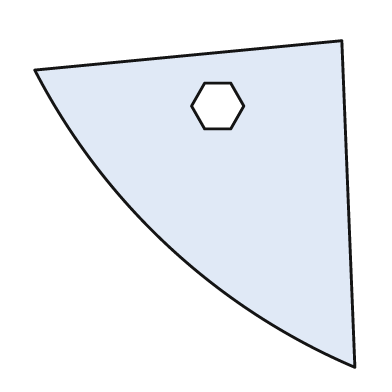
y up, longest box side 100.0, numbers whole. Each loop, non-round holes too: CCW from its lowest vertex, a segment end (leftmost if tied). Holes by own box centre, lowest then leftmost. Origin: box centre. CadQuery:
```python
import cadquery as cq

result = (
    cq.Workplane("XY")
    .moveTo(49.0, -50.0)
    .lineTo(45.0, 50.0)
    .lineTo(-49.0, 41.0)
    .threePointArc((-8.0, -13.0), (49.0, -50.0))
    .close()
    .moveTo(3.0, 23.0)
    .lineTo(11.0, 23.0)
    .lineTo(15.0, 30.0)
    .lineTo(11.0, 37.0)
    .lineTo(3.0, 37.0)
    .lineTo(-1.0, 30.0)
    .close()
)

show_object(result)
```